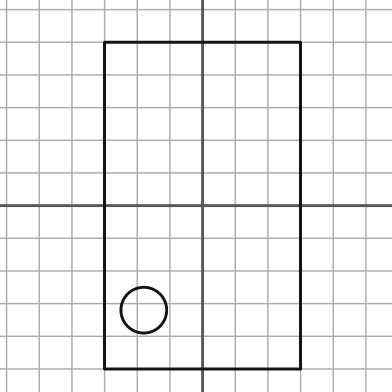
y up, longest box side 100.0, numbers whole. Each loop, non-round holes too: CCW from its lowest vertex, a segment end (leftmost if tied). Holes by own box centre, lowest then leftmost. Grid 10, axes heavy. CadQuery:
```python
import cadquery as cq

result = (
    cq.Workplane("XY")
    .moveTo(-30.0, -50.0)
    .lineTo(30.0, -50.0)
    .lineTo(30.0, 50.0)
    .lineTo(-30.0, 50.0)
    .close()
    .moveTo(-18.0, -32.0)
    .circle(7.0)
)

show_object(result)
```